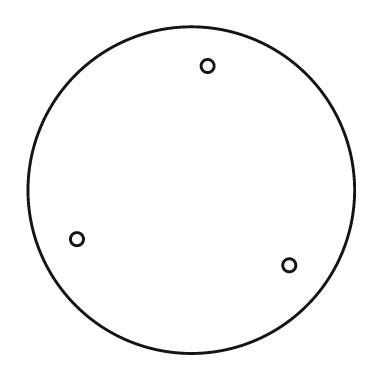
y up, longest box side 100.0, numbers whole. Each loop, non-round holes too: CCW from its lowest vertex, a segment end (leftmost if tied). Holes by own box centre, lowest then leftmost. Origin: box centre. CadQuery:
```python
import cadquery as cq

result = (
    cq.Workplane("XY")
    .moveTo(0.0, 0.0)
    .circle(50.0)
    .moveTo(30.0, -23.0)
    .circle(2.0)
    .moveTo(-35.0, -15.0)
    .circle(2.0)
    .moveTo(5.0, 38.0)
    .circle(2.0)
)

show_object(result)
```